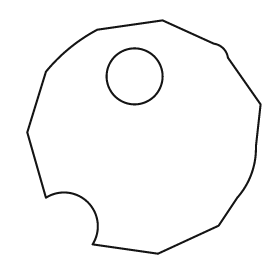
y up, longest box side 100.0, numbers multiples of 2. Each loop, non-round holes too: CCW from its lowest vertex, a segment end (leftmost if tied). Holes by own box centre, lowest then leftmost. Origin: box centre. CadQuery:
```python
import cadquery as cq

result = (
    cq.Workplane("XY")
    .moveTo(6.0, -50.0)
    .lineTo(32.0, -38.0)
    .lineTo(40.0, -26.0)
    .threePointArc((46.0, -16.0), (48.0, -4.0))
    .lineTo(50.0, 14.0)
    .lineTo(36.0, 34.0)
    .threePointArc((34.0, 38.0), (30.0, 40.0))
    .lineTo(8.0, 50.0)
    .lineTo(-20.0, 46.0)
    .threePointArc((-32.0, 38.0), (-42.0, 28.0))
    .lineTo(-50.0, 2.0)
    .lineTo(-42.0, -26.0)
    .threePointArc((-24.0, -28.0), (-22.0, -46.0))
    .close()
    .moveTo(-4.0, 26.0)
    .circle(12.0)
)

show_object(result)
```